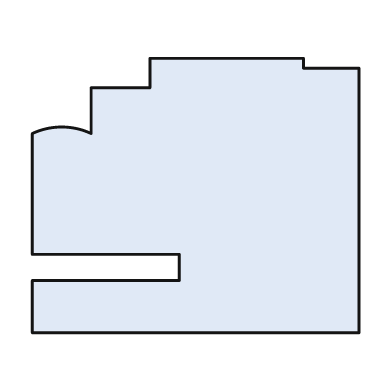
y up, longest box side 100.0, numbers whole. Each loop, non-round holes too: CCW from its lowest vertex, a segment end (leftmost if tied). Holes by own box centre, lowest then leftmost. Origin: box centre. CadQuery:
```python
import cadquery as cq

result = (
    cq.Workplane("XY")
    .moveTo(-50.0, -42.0)
    .lineTo(50.0, -42.0)
    .lineTo(50.0, 39.0)
    .lineTo(33.0, 39.0)
    .lineTo(33.0, 42.0)
    .lineTo(-14.0, 42.0)
    .lineTo(-14.0, 33.0)
    .lineTo(-32.0, 33.0)
    .lineTo(-32.0, 19.0)
    .threePointArc((-41.0, 21.0), (-50.0, 19.0))
    .lineTo(-50.0, -18.0)
    .lineTo(-5.0, -18.0)
    .lineTo(-5.0, -26.0)
    .lineTo(-50.0, -26.0)
    .close()
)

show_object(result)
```